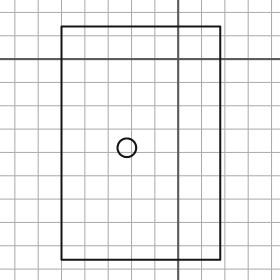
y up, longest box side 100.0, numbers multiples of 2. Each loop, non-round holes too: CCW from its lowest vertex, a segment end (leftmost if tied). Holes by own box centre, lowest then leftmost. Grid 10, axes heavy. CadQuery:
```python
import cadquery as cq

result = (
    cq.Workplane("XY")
    .moveTo(-50.0, -86.0)
    .lineTo(18.0, -86.0)
    .lineTo(18.0, 14.0)
    .lineTo(-50.0, 14.0)
    .close()
    .moveTo(-22.0, -38.0)
    .circle(4.0)
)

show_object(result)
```